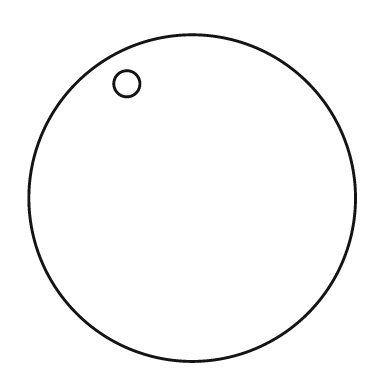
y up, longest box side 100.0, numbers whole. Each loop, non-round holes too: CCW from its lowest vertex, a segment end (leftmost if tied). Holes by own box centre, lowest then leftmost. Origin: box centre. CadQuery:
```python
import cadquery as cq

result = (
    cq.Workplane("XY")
    .moveTo(0.0, 0.0)
    .circle(50.0)
    .moveTo(-20.0, 35.0)
    .circle(4.0)
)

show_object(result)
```